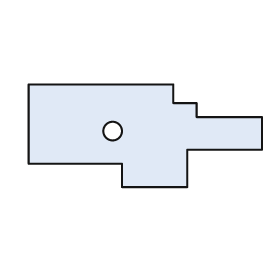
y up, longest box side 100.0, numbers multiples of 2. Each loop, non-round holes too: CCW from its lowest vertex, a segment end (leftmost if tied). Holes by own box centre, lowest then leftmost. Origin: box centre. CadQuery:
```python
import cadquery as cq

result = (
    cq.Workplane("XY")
    .moveTo(-10.0, -22.0)
    .lineTo(18.0, -22.0)
    .lineTo(18.0, -6.0)
    .lineTo(50.0, -6.0)
    .lineTo(50.0, 8.0)
    .lineTo(22.0, 8.0)
    .lineTo(22.0, 14.0)
    .lineTo(12.0, 14.0)
    .lineTo(12.0, 22.0)
    .lineTo(-50.0, 22.0)
    .lineTo(-50.0, -12.0)
    .lineTo(-10.0, -12.0)
    .close()
    .moveTo(-14.0, 2.0)
    .circle(4.0)
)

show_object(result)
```